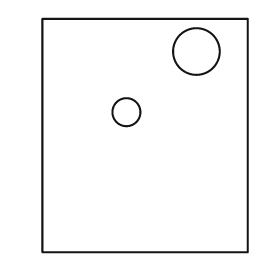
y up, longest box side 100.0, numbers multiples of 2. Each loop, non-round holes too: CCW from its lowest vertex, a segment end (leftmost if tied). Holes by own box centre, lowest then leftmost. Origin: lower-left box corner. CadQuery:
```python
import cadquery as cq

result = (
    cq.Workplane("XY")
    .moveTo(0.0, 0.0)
    .lineTo(88.0, 0.0)
    .lineTo(88.0, 100.0)
    .lineTo(0.0, 100.0)
    .close()
    .moveTo(36.0, 60.0)
    .circle(6.0)
    .moveTo(66.0, 86.0)
    .circle(10.0)
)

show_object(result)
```